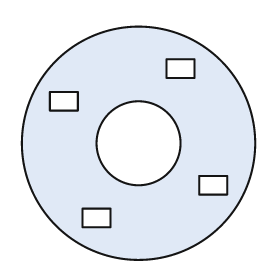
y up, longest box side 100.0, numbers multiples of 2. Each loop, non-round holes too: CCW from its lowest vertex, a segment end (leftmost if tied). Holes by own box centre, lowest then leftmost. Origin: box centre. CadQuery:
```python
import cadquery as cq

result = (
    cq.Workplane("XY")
    .moveTo(0.0, 0.0)
    .circle(50.0)
    .moveTo(-24.0, -36.0)
    .lineTo(-12.0, -36.0)
    .lineTo(-12.0, -28.0)
    .lineTo(-24.0, -28.0)
    .close()
    .moveTo(26.0, -22.0)
    .lineTo(38.0, -22.0)
    .lineTo(38.0, -14.0)
    .lineTo(26.0, -14.0)
    .close()
    .moveTo(0.0, 0.0)
    .circle(18.0)
    .moveTo(-38.0, 14.0)
    .lineTo(-26.0, 14.0)
    .lineTo(-26.0, 22.0)
    .lineTo(-38.0, 22.0)
    .close()
    .moveTo(12.0, 28.0)
    .lineTo(24.0, 28.0)
    .lineTo(24.0, 36.0)
    .lineTo(12.0, 36.0)
    .close()
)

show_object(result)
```